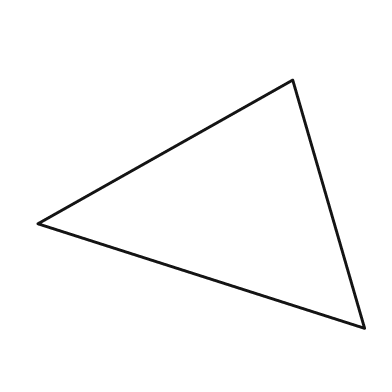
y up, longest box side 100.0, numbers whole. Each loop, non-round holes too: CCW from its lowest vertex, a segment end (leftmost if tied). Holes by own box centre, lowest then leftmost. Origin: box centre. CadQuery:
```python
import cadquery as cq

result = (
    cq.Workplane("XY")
    .moveTo(50.0, -38.0)
    .lineTo(28.0, 38.0)
    .lineTo(-50.0, -6.0)
    .close()
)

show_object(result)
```